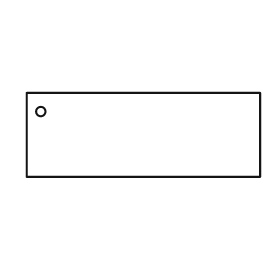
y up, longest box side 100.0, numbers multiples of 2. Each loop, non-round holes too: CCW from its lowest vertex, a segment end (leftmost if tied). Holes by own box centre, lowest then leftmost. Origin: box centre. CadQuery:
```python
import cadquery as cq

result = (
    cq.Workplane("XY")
    .moveTo(-50.0, -18.0)
    .lineTo(50.0, -18.0)
    .lineTo(50.0, 18.0)
    .lineTo(-50.0, 18.0)
    .close()
    .moveTo(-44.0, 10.0)
    .circle(2.0)
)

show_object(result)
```